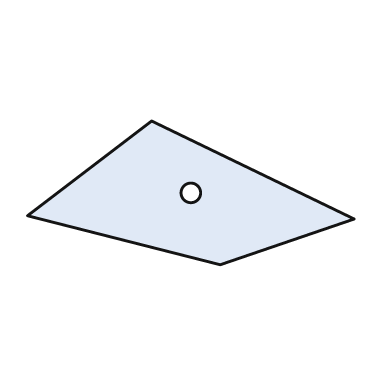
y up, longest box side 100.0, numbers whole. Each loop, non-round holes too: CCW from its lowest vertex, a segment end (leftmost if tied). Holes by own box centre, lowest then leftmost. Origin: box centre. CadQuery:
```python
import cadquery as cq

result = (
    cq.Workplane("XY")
    .moveTo(9.0, -22.0)
    .lineTo(50.0, -8.0)
    .lineTo(-12.0, 22.0)
    .lineTo(-50.0, -7.0)
    .close()
    .moveTo(0.0, 0.0)
    .circle(3.0)
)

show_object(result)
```